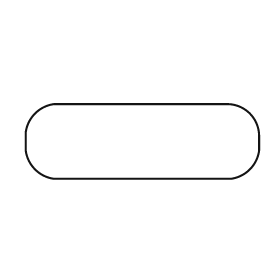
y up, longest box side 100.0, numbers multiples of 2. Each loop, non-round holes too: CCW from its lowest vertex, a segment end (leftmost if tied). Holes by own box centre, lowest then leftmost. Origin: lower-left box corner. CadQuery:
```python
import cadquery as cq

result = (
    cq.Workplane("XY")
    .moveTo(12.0, 0.0)
    .lineTo(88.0, 0.0)
    .threePointArc((96.0, 4.0), (100.0, 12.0))
    .lineTo(100.0, 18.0)
    .threePointArc((96.0, 28.0), (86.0, 32.0))
    .lineTo(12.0, 32.0)
    .threePointArc((4.0, 28.0), (0.0, 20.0))
    .lineTo(0.0, 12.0)
    .threePointArc((4.0, 4.0), (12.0, 0.0))
    .close()
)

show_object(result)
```